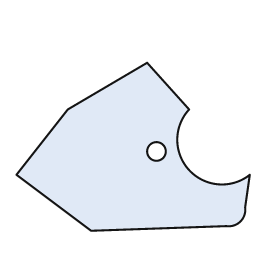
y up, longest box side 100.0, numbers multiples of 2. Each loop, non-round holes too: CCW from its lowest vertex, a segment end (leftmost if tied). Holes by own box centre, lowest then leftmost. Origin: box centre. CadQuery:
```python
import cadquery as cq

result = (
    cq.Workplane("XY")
    .moveTo(-18.0, -36.0)
    .lineTo(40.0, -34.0)
    .threePointArc((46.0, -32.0), (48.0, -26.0))
    .lineTo(50.0, -12.0)
    .threePointArc((24.0, -10.0), (24.0, 16.0))
    .lineTo(6.0, 36.0)
    .lineTo(-28.0, 16.0)
    .lineTo(-50.0, -12.0)
    .close()
    .moveTo(10.0, -2.0)
    .circle(4.0)
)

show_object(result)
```